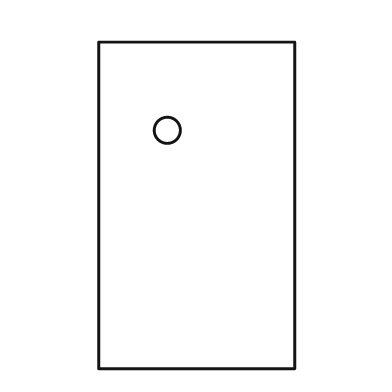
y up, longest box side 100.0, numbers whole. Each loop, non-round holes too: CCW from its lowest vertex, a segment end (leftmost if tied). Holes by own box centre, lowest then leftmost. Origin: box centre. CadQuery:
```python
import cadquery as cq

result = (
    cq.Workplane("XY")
    .moveTo(-30.0, -50.0)
    .lineTo(30.0, -50.0)
    .lineTo(30.0, 50.0)
    .lineTo(-30.0, 50.0)
    .close()
    .moveTo(-9.0, 23.0)
    .circle(4.0)
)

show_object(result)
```